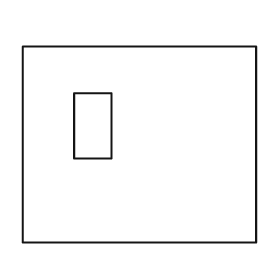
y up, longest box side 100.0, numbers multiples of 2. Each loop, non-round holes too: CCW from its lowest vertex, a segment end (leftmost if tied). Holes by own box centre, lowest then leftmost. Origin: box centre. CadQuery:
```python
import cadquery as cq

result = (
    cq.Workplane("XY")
    .moveTo(-50.0, -42.0)
    .lineTo(50.0, -42.0)
    .lineTo(50.0, 42.0)
    .lineTo(-50.0, 42.0)
    .close()
    .moveTo(-28.0, -6.0)
    .lineTo(-12.0, -6.0)
    .lineTo(-12.0, 22.0)
    .lineTo(-28.0, 22.0)
    .close()
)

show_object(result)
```